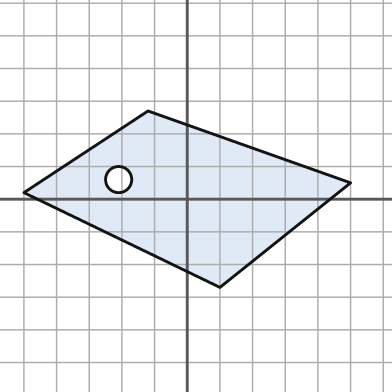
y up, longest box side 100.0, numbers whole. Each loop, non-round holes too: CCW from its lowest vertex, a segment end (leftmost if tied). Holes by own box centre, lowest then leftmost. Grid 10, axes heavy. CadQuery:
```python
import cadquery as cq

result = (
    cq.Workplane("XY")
    .moveTo(10.0, -27.0)
    .lineTo(50.0, 5.0)
    .lineTo(-12.0, 27.0)
    .lineTo(-50.0, 2.0)
    .close()
    .moveTo(-21.0, 6.0)
    .circle(4.0)
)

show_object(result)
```